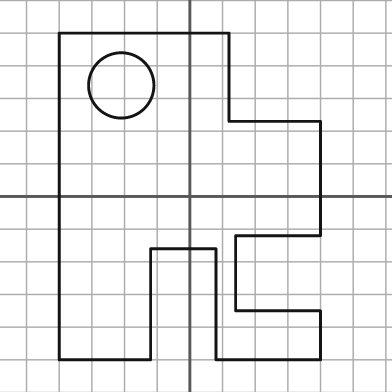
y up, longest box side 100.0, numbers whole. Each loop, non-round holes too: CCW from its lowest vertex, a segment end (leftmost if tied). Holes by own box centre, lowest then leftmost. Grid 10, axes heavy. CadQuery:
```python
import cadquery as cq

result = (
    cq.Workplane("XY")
    .moveTo(-40.0, -50.0)
    .lineTo(-12.0, -50.0)
    .lineTo(-12.0, -16.0)
    .lineTo(8.0, -16.0)
    .lineTo(8.0, -50.0)
    .lineTo(40.0, -50.0)
    .lineTo(40.0, -35.0)
    .lineTo(14.0, -35.0)
    .lineTo(14.0, -12.0)
    .lineTo(40.0, -12.0)
    .lineTo(40.0, 23.0)
    .lineTo(12.0, 23.0)
    .lineTo(12.0, 50.0)
    .lineTo(-40.0, 50.0)
    .close()
    .moveTo(-21.0, 34.0)
    .circle(10.0)
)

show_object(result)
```